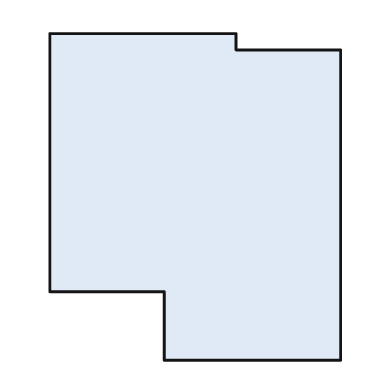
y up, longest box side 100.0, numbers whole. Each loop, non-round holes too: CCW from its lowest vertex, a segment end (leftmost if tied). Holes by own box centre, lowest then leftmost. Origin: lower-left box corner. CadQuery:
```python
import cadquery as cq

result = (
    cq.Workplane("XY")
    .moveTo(35.0, 0.0)
    .lineTo(89.0, 0.0)
    .lineTo(89.0, 95.0)
    .lineTo(57.0, 95.0)
    .lineTo(57.0, 100.0)
    .lineTo(0.0, 100.0)
    .lineTo(0.0, 21.0)
    .lineTo(35.0, 21.0)
    .close()
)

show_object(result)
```